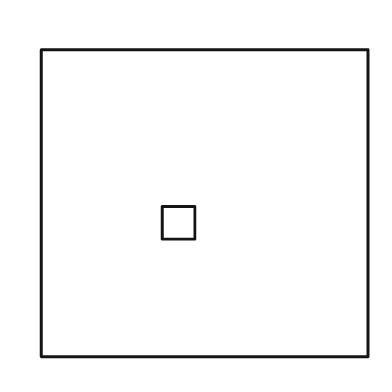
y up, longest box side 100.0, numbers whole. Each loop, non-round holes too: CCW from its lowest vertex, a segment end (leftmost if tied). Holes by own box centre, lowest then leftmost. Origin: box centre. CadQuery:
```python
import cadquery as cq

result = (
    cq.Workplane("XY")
    .moveTo(-50.0, -47.0)
    .lineTo(50.0, -47.0)
    .lineTo(50.0, 47.0)
    .lineTo(-50.0, 47.0)
    .close()
    .moveTo(-13.0, -11.0)
    .lineTo(-3.0, -11.0)
    .lineTo(-3.0, -1.0)
    .lineTo(-13.0, -1.0)
    .close()
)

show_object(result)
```